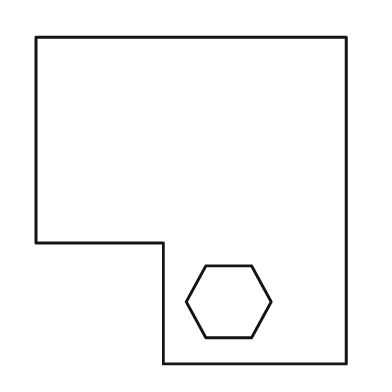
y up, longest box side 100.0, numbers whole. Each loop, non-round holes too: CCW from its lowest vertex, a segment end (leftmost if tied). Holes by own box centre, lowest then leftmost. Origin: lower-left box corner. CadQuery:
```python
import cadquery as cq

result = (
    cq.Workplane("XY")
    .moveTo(39.0, 0.0)
    .lineTo(95.0, 0.0)
    .lineTo(95.0, 100.0)
    .lineTo(0.0, 100.0)
    .lineTo(0.0, 37.0)
    .lineTo(39.0, 37.0)
    .close()
    .moveTo(52.0, 8.0)
    .lineTo(66.0, 8.0)
    .lineTo(72.0, 19.0)
    .lineTo(66.0, 30.0)
    .lineTo(52.0, 30.0)
    .lineTo(46.0, 19.0)
    .close()
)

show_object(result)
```